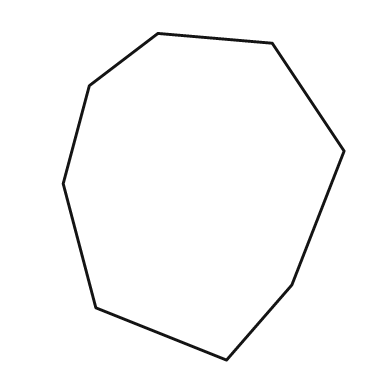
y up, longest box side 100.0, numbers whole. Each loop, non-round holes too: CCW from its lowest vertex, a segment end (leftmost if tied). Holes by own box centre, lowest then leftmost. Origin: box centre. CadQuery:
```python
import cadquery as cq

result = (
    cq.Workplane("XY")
    .moveTo(7.0, -50.0)
    .lineTo(27.0, -27.0)
    .lineTo(43.0, 14.0)
    .lineTo(21.0, 47.0)
    .lineTo(-14.0, 50.0)
    .lineTo(-35.0, 34.0)
    .lineTo(-43.0, 4.0)
    .lineTo(-33.0, -34.0)
    .close()
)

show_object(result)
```